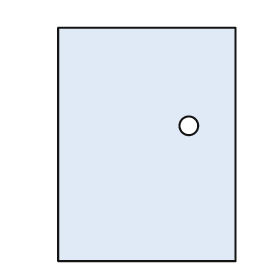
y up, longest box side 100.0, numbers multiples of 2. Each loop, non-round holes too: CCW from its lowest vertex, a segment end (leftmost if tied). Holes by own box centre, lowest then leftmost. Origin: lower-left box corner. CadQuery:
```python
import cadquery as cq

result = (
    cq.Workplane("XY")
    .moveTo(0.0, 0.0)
    .lineTo(76.0, 0.0)
    .lineTo(76.0, 100.0)
    .lineTo(0.0, 100.0)
    .close()
    .moveTo(56.0, 58.0)
    .circle(4.0)
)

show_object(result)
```